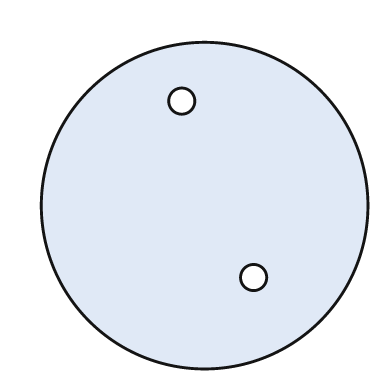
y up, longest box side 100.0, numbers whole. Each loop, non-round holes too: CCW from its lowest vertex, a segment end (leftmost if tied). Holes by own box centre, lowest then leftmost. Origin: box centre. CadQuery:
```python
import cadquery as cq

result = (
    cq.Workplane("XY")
    .moveTo(0.0, 0.0)
    .circle(50.0)
    .moveTo(15.0, -22.0)
    .circle(4.0)
    .moveTo(-7.0, 32.0)
    .circle(4.0)
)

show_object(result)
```